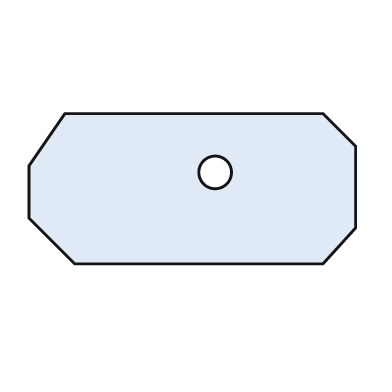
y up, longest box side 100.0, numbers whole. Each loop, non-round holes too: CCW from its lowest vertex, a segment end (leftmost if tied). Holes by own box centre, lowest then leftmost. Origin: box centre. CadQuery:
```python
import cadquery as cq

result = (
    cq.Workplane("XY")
    .moveTo(-36.0, -23.0)
    .lineTo(40.0, -23.0)
    .lineTo(50.0, -12.0)
    .lineTo(50.0, 13.0)
    .lineTo(40.0, 23.0)
    .lineTo(-39.0, 23.0)
    .lineTo(-50.0, 7.0)
    .lineTo(-50.0, -9.0)
    .close()
    .moveTo(7.0, 5.0)
    .circle(5.0)
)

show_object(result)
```